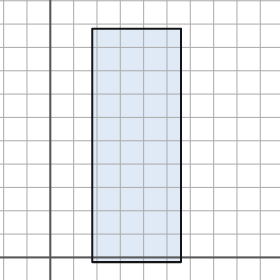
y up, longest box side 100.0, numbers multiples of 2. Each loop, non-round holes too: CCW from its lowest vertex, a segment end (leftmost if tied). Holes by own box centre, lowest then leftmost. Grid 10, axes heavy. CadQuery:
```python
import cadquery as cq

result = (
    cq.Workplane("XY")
    .moveTo(18.0, -2.0)
    .lineTo(56.0, -2.0)
    .lineTo(56.0, 98.0)
    .lineTo(18.0, 98.0)
    .close()
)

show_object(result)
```